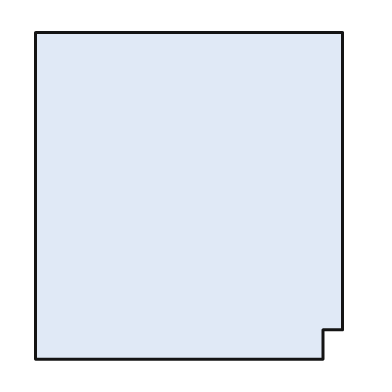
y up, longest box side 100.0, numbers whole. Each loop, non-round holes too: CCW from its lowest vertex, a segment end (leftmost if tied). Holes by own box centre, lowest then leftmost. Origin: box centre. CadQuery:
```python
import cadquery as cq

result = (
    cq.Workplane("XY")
    .moveTo(-47.0, -50.0)
    .lineTo(41.0, -50.0)
    .lineTo(41.0, -41.0)
    .lineTo(47.0, -41.0)
    .lineTo(47.0, 50.0)
    .lineTo(-47.0, 50.0)
    .close()
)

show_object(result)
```